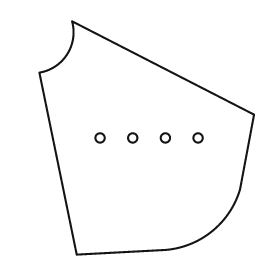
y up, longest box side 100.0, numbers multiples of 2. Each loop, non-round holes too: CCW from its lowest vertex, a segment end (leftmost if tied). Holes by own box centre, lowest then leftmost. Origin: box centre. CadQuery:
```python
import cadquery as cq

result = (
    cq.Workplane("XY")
    .moveTo(-30.0, -50.0)
    .lineTo(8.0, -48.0)
    .threePointArc((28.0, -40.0), (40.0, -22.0))
    .lineTo(46.0, 10.0)
    .lineTo(-32.0, 50.0)
    .threePointArc((-34.0, 36.0), (-46.0, 28.0))
    .close()
    .moveTo(-20.0, 0.0)
    .circle(2.0)
    .moveTo(-6.0, 0.0)
    .circle(2.0)
    .moveTo(8.0, 0.0)
    .circle(2.0)
    .moveTo(22.0, 0.0)
    .circle(2.0)
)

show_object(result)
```